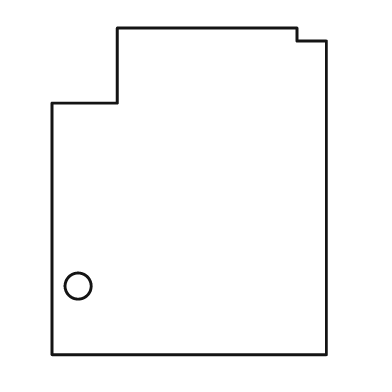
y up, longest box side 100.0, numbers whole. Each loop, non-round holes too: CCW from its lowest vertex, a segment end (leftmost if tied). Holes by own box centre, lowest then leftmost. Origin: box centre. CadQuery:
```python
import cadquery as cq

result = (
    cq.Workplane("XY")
    .moveTo(-42.0, -50.0)
    .lineTo(42.0, -50.0)
    .lineTo(42.0, 46.0)
    .lineTo(33.0, 46.0)
    .lineTo(33.0, 50.0)
    .lineTo(-22.0, 50.0)
    .lineTo(-22.0, 27.0)
    .lineTo(-42.0, 27.0)
    .close()
    .moveTo(-34.0, -29.0)
    .circle(4.0)
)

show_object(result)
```